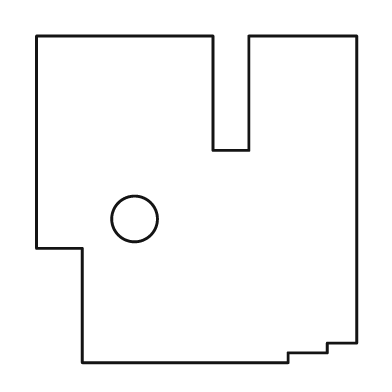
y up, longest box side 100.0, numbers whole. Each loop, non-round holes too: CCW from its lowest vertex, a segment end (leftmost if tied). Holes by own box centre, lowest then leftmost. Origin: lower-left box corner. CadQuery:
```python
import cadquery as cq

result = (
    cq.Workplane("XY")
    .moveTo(14.0, 0.0)
    .lineTo(77.0, 0.0)
    .lineTo(77.0, 3.0)
    .lineTo(89.0, 3.0)
    .lineTo(89.0, 6.0)
    .lineTo(98.0, 6.0)
    .lineTo(98.0, 100.0)
    .lineTo(65.0, 100.0)
    .lineTo(65.0, 65.0)
    .lineTo(54.0, 65.0)
    .lineTo(54.0, 100.0)
    .lineTo(0.0, 100.0)
    .lineTo(0.0, 35.0)
    .lineTo(14.0, 35.0)
    .close()
    .moveTo(30.0, 44.0)
    .circle(7.0)
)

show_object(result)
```